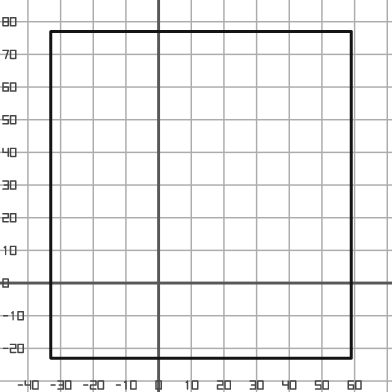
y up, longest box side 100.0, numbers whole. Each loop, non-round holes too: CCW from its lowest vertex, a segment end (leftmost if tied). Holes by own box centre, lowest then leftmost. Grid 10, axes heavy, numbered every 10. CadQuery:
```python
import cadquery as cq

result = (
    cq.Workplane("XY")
    .moveTo(-33.0, -23.0)
    .lineTo(59.0, -23.0)
    .lineTo(59.0, 77.0)
    .lineTo(-33.0, 77.0)
    .close()
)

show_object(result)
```